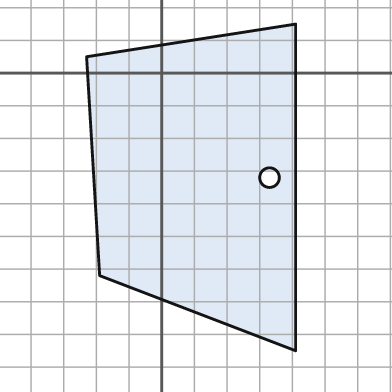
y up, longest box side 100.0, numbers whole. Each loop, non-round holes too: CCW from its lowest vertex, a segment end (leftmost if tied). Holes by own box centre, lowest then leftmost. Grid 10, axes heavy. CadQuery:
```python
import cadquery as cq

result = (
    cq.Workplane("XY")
    .moveTo(41.0, -85.0)
    .lineTo(41.0, 15.0)
    .lineTo(-23.0, 5.0)
    .lineTo(-19.0, -62.0)
    .close()
    .moveTo(33.0, -32.0)
    .circle(3.0)
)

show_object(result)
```